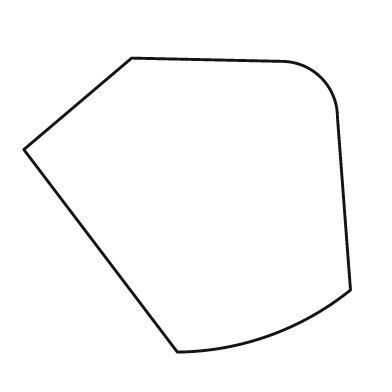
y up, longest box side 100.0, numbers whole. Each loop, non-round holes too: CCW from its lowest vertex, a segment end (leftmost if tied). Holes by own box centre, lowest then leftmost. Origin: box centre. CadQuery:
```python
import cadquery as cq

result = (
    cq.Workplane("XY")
    .moveTo(-3.0, -45.0)
    .threePointArc((25.0, -40.0), (50.0, -26.0))
    .lineTo(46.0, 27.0)
    .threePointArc((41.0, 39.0), (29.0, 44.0))
    .lineTo(-17.0, 45.0)
    .lineTo(-50.0, 17.0)
    .close()
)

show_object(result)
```